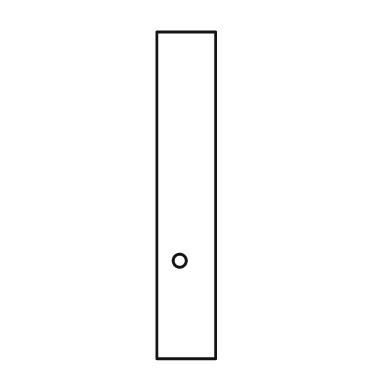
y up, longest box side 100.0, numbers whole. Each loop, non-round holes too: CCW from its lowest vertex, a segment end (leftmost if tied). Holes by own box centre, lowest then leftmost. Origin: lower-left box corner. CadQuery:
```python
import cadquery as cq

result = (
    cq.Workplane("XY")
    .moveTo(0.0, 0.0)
    .lineTo(18.0, 0.0)
    .lineTo(18.0, 100.0)
    .lineTo(0.0, 100.0)
    .close()
    .moveTo(7.0, 30.0)
    .circle(2.0)
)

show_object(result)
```